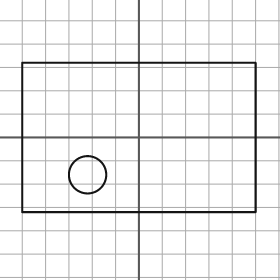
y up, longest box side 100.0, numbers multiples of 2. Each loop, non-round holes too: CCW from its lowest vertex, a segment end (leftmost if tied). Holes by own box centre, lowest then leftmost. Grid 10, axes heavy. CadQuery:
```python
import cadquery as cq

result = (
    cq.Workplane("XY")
    .moveTo(-50.0, -32.0)
    .lineTo(50.0, -32.0)
    .lineTo(50.0, 32.0)
    .lineTo(-50.0, 32.0)
    .close()
    .moveTo(-22.0, -16.0)
    .circle(8.0)
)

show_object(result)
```